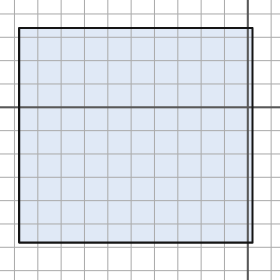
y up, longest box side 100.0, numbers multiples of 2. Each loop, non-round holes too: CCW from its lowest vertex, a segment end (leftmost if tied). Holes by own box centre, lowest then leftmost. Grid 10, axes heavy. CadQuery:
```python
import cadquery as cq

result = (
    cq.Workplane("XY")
    .moveTo(-98.0, -58.0)
    .lineTo(2.0, -58.0)
    .lineTo(2.0, 34.0)
    .lineTo(-98.0, 34.0)
    .close()
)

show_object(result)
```